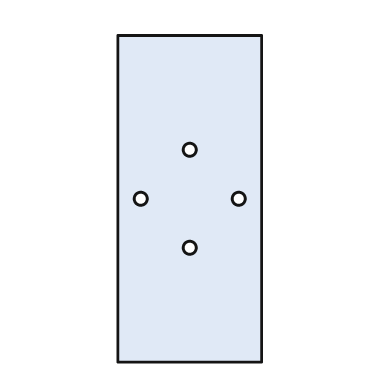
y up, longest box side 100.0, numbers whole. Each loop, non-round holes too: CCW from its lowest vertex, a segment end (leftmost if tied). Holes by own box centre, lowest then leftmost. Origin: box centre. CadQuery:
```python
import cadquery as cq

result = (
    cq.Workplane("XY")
    .moveTo(-22.0, -50.0)
    .lineTo(22.0, -50.0)
    .lineTo(22.0, 50.0)
    .lineTo(-22.0, 50.0)
    .close()
    .moveTo(0.0, -15.0)
    .circle(2.0)
    .moveTo(-15.0, 0.0)
    .circle(2.0)
    .moveTo(15.0, 0.0)
    .circle(2.0)
    .moveTo(0.0, 15.0)
    .circle(2.0)
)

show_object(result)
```